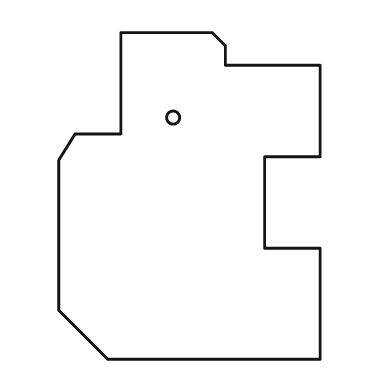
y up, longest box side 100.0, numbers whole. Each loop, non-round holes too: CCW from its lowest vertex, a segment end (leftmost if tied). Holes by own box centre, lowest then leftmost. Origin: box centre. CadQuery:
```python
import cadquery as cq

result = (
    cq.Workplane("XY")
    .moveTo(-25.0, -50.0)
    .lineTo(40.0, -50.0)
    .lineTo(40.0, -16.0)
    .lineTo(23.0, -16.0)
    .lineTo(23.0, 12.0)
    .lineTo(40.0, 12.0)
    .lineTo(40.0, 40.0)
    .lineTo(11.0, 40.0)
    .lineTo(11.0, 46.0)
    .lineTo(7.0, 50.0)
    .lineTo(-21.0, 50.0)
    .lineTo(-21.0, 19.0)
    .lineTo(-35.0, 19.0)
    .lineTo(-40.0, 11.0)
    .lineTo(-40.0, -35.0)
    .close()
    .moveTo(-5.0, 24.0)
    .circle(2.0)
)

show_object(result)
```